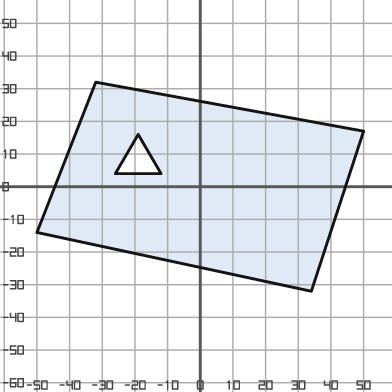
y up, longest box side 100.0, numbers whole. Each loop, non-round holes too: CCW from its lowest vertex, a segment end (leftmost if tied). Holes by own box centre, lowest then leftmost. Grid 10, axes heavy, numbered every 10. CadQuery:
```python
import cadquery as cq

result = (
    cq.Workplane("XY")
    .moveTo(34.0, -32.0)
    .lineTo(50.0, 17.0)
    .lineTo(-32.0, 32.0)
    .lineTo(-50.0, -14.0)
    .close()
    .moveTo(-26.0, 4.0)
    .lineTo(-12.0, 4.0)
    .lineTo(-19.0, 16.0)
    .close()
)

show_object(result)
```